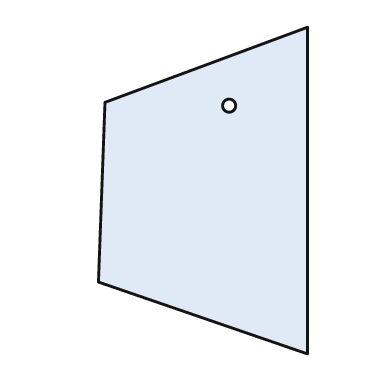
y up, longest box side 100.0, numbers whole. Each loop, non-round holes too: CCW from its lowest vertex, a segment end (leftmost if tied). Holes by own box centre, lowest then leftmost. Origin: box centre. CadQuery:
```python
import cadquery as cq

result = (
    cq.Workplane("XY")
    .moveTo(32.0, -50.0)
    .lineTo(32.0, 50.0)
    .lineTo(-30.0, 27.0)
    .lineTo(-32.0, -28.0)
    .close()
    .moveTo(8.0, 26.0)
    .circle(2.0)
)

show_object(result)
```